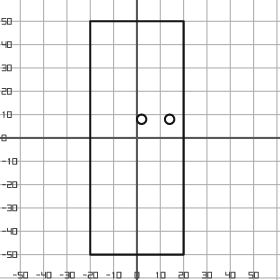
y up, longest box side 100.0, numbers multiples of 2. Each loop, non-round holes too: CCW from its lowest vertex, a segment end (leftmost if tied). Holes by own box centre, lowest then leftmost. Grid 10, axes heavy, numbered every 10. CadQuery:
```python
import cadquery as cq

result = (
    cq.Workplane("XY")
    .moveTo(-20.0, -50.0)
    .lineTo(20.0, -50.0)
    .lineTo(20.0, 50.0)
    .lineTo(-20.0, 50.0)
    .close()
    .moveTo(2.0, 8.0)
    .circle(2.0)
    .moveTo(14.0, 8.0)
    .circle(2.0)
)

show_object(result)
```